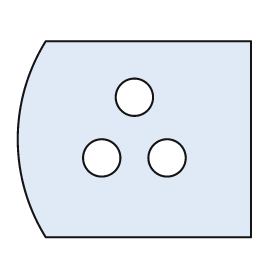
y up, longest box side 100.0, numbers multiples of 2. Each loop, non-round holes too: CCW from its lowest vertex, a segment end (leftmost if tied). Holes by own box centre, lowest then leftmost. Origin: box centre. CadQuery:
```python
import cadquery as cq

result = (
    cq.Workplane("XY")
    .moveTo(-38.0, -42.0)
    .lineTo(50.0, -42.0)
    .lineTo(50.0, 42.0)
    .lineTo(-38.0, 42.0)
    .threePointArc((-50.0, 0.0), (-38.0, -42.0))
    .close()
    .moveTo(-14.0, -8.0)
    .circle(8.0)
    .moveTo(14.0, -8.0)
    .circle(8.0)
    .moveTo(0.0, 18.0)
    .circle(8.0)
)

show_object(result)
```